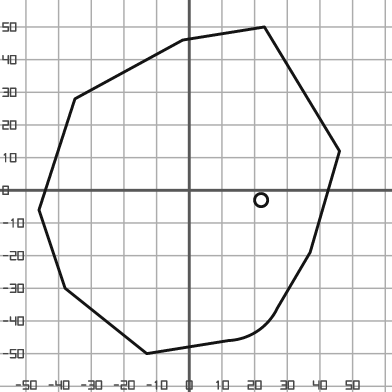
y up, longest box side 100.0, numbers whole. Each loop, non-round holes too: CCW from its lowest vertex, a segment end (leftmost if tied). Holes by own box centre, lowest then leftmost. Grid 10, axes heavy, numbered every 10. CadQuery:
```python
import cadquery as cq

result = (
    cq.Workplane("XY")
    .moveTo(-13.0, -50.0)
    .lineTo(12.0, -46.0)
    .threePointArc((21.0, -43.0), (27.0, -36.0))
    .lineTo(37.0, -19.0)
    .lineTo(46.0, 12.0)
    .lineTo(23.0, 50.0)
    .lineTo(-2.0, 46.0)
    .lineTo(-35.0, 28.0)
    .lineTo(-46.0, -6.0)
    .lineTo(-38.0, -30.0)
    .close()
    .moveTo(22.0, -3.0)
    .circle(2.0)
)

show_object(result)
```